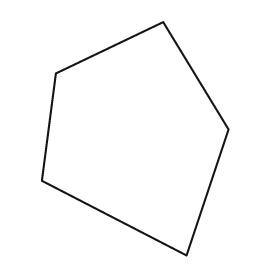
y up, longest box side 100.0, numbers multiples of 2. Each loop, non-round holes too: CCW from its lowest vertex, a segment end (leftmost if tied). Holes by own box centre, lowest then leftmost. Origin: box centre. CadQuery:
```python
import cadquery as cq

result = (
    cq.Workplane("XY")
    .moveTo(22.0, -50.0)
    .lineTo(40.0, 4.0)
    .lineTo(12.0, 50.0)
    .lineTo(-34.0, 28.0)
    .lineTo(-40.0, -18.0)
    .close()
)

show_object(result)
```